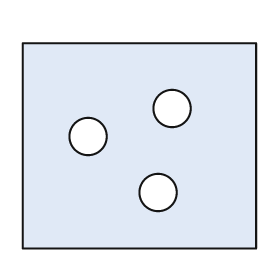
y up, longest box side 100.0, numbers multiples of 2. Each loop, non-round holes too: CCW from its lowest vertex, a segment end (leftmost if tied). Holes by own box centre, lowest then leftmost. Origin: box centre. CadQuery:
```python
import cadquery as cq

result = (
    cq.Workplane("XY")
    .moveTo(-50.0, -44.0)
    .lineTo(50.0, -44.0)
    .lineTo(50.0, 44.0)
    .lineTo(-50.0, 44.0)
    .close()
    .moveTo(8.0, -20.0)
    .circle(8.0)
    .moveTo(-22.0, 4.0)
    .circle(8.0)
    .moveTo(14.0, 16.0)
    .circle(8.0)
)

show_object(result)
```